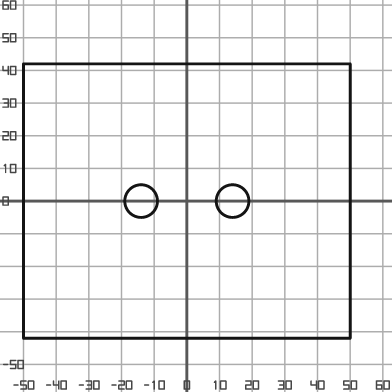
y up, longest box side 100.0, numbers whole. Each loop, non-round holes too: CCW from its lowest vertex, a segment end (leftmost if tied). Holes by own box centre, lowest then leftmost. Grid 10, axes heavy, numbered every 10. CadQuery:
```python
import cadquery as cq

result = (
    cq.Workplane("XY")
    .moveTo(-50.0, -42.0)
    .lineTo(50.0, -42.0)
    .lineTo(50.0, 42.0)
    .lineTo(-50.0, 42.0)
    .close()
    .moveTo(-14.0, 0.0)
    .circle(5.0)
    .moveTo(14.0, 0.0)
    .circle(5.0)
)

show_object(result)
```